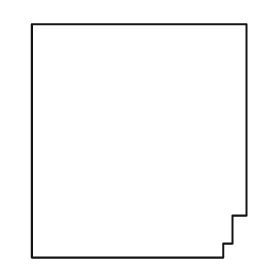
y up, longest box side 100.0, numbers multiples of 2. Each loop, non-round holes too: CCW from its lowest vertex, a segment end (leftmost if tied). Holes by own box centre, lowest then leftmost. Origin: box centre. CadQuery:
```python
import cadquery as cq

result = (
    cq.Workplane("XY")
    .moveTo(-46.0, -50.0)
    .lineTo(36.0, -50.0)
    .lineTo(36.0, -44.0)
    .lineTo(40.0, -44.0)
    .lineTo(40.0, -32.0)
    .lineTo(46.0, -32.0)
    .lineTo(46.0, 50.0)
    .lineTo(-46.0, 50.0)
    .close()
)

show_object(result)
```